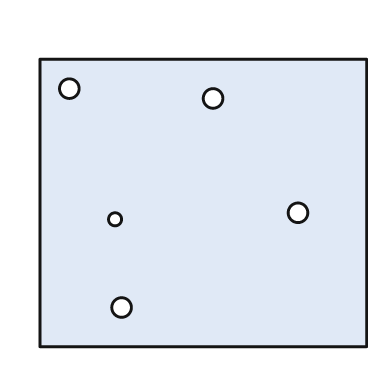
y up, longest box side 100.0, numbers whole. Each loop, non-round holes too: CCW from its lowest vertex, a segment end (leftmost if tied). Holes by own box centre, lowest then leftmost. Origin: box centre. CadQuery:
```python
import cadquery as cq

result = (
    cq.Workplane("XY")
    .moveTo(-50.0, -44.0)
    .lineTo(50.0, -44.0)
    .lineTo(50.0, 44.0)
    .lineTo(-50.0, 44.0)
    .close()
    .moveTo(-25.0, -32.0)
    .circle(3.0)
    .moveTo(-27.0, -5.0)
    .circle(2.0)
    .moveTo(29.0, -3.0)
    .circle(3.0)
    .moveTo(3.0, 32.0)
    .circle(3.0)
    .moveTo(-41.0, 35.0)
    .circle(3.0)
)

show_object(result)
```